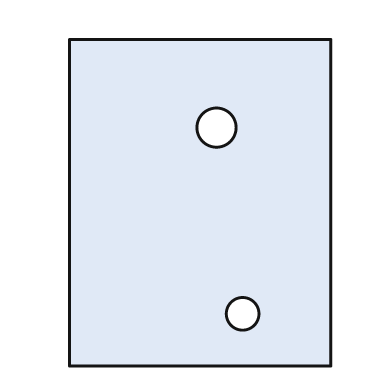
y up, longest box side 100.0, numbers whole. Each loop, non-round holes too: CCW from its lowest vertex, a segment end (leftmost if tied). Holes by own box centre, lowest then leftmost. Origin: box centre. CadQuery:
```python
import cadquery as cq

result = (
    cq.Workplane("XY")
    .moveTo(-40.0, -50.0)
    .lineTo(40.0, -50.0)
    .lineTo(40.0, 50.0)
    .lineTo(-40.0, 50.0)
    .close()
    .moveTo(13.0, -34.0)
    .circle(5.0)
    .moveTo(5.0, 23.0)
    .circle(6.0)
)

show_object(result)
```